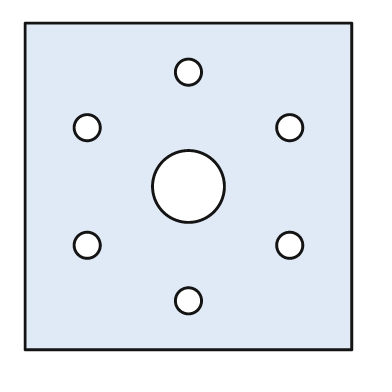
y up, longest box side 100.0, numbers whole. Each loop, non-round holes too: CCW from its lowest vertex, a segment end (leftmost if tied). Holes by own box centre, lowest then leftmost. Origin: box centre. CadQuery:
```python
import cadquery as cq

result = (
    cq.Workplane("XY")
    .moveTo(-50.0, -50.0)
    .lineTo(50.0, -50.0)
    .lineTo(50.0, 50.0)
    .lineTo(-50.0, 50.0)
    .close()
    .moveTo(0.0, -35.0)
    .circle(4.0)
    .moveTo(-31.0, -18.0)
    .circle(4.0)
    .moveTo(31.0, -18.0)
    .circle(4.0)
    .moveTo(0.0, 0.0)
    .circle(11.0)
    .moveTo(-31.0, 18.0)
    .circle(4.0)
    .moveTo(31.0, 18.0)
    .circle(4.0)
    .moveTo(0.0, 35.0)
    .circle(4.0)
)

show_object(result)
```